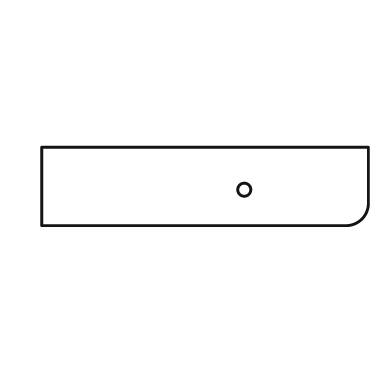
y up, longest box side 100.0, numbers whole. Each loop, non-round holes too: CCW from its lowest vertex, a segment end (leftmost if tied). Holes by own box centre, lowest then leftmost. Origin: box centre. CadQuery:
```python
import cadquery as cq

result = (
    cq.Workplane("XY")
    .moveTo(-50.0, -12.0)
    .lineTo(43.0, -12.0)
    .threePointArc((48.0, -10.0), (50.0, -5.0))
    .lineTo(50.0, 12.0)
    .lineTo(-50.0, 12.0)
    .close()
    .moveTo(12.0, -1.0)
    .circle(2.0)
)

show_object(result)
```